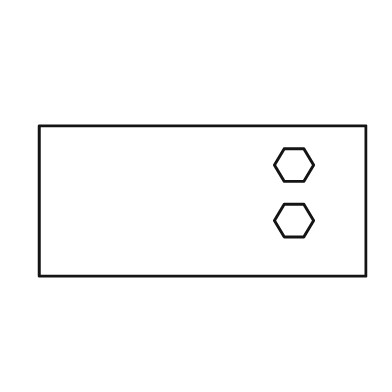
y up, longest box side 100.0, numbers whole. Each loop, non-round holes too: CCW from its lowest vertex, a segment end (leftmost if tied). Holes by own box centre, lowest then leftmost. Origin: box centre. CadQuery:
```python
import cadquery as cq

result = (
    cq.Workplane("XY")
    .moveTo(-50.0, -23.0)
    .lineTo(50.0, -23.0)
    .lineTo(50.0, 23.0)
    .lineTo(-50.0, 23.0)
    .close()
    .moveTo(25.0, -11.0)
    .lineTo(31.0, -11.0)
    .lineTo(34.0, -6.0)
    .lineTo(31.0, -1.0)
    .lineTo(25.0, -1.0)
    .lineTo(22.0, -6.0)
    .close()
    .moveTo(25.0, 6.0)
    .lineTo(31.0, 6.0)
    .lineTo(34.0, 11.0)
    .lineTo(31.0, 16.0)
    .lineTo(25.0, 16.0)
    .lineTo(22.0, 11.0)
    .close()
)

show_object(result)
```